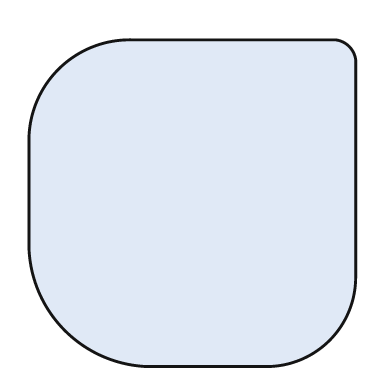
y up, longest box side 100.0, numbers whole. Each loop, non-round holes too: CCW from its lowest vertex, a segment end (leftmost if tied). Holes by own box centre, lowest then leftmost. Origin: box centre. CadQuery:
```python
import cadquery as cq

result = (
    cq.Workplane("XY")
    .moveTo(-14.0, -50.0)
    .lineTo(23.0, -50.0)
    .threePointArc((42.0, -42.0), (50.0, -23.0))
    .lineTo(50.0, 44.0)
    .threePointArc((48.0, 48.0), (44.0, 50.0))
    .lineTo(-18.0, 50.0)
    .threePointArc((-41.0, 41.0), (-50.0, 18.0))
    .lineTo(-50.0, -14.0)
    .threePointArc((-39.0, -39.0), (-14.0, -50.0))
    .close()
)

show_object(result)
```